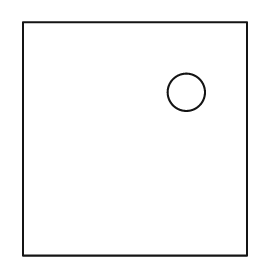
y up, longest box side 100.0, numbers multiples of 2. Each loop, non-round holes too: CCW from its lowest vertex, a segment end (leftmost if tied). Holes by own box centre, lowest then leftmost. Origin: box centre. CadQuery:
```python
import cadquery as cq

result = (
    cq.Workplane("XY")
    .moveTo(-48.0, -50.0)
    .lineTo(48.0, -50.0)
    .lineTo(48.0, 50.0)
    .lineTo(-48.0, 50.0)
    .close()
    .moveTo(22.0, 20.0)
    .circle(8.0)
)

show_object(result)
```